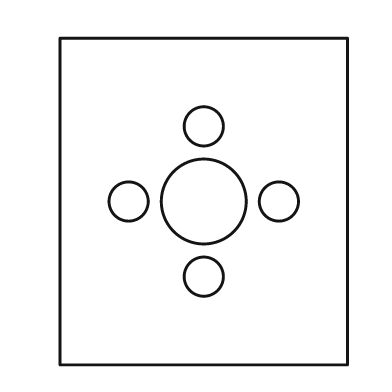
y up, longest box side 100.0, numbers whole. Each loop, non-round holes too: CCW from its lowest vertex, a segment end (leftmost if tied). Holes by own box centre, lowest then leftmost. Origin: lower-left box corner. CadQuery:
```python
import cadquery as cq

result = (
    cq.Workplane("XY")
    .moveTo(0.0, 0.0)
    .lineTo(88.0, 0.0)
    .lineTo(88.0, 100.0)
    .lineTo(0.0, 100.0)
    .close()
    .moveTo(44.0, 27.0)
    .circle(6.0)
    .moveTo(21.0, 50.0)
    .circle(6.0)
    .moveTo(44.0, 50.0)
    .circle(13.0)
    .moveTo(67.0, 50.0)
    .circle(6.0)
    .moveTo(44.0, 73.0)
    .circle(6.0)
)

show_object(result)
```